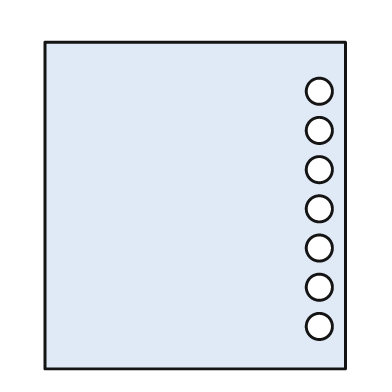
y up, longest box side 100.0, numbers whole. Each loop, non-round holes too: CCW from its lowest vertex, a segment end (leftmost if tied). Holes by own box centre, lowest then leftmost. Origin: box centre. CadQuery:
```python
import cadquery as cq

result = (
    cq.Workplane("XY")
    .moveTo(-46.0, -50.0)
    .lineTo(46.0, -50.0)
    .lineTo(46.0, 50.0)
    .lineTo(-46.0, 50.0)
    .close()
    .moveTo(38.0, -37.0)
    .circle(4.0)
    .moveTo(38.0, -25.0)
    .circle(4.0)
    .moveTo(38.0, -13.0)
    .circle(4.0)
    .moveTo(38.0, -1.0)
    .circle(4.0)
    .moveTo(38.0, 11.0)
    .circle(4.0)
    .moveTo(38.0, 23.0)
    .circle(4.0)
    .moveTo(38.0, 35.0)
    .circle(4.0)
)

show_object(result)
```